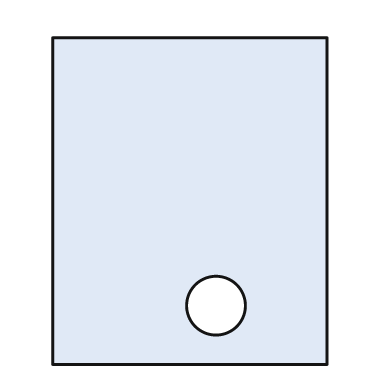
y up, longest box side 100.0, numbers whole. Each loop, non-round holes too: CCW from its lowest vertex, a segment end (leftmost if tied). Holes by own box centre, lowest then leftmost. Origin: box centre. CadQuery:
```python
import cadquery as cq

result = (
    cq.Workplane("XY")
    .moveTo(-42.0, -50.0)
    .lineTo(42.0, -50.0)
    .lineTo(42.0, 50.0)
    .lineTo(-42.0, 50.0)
    .close()
    .moveTo(8.0, -32.0)
    .circle(9.0)
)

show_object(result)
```